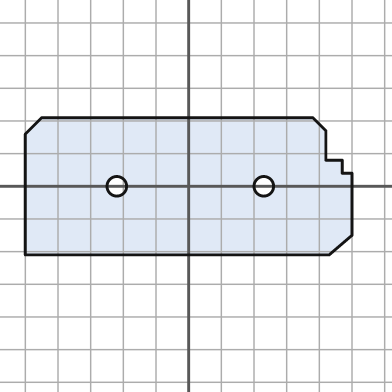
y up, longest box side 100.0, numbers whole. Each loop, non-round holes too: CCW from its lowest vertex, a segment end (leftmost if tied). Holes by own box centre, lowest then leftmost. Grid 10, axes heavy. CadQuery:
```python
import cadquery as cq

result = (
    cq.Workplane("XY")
    .moveTo(-50.0, -21.0)
    .lineTo(43.0, -21.0)
    .lineTo(50.0, -15.0)
    .lineTo(50.0, 4.0)
    .lineTo(47.0, 4.0)
    .lineTo(47.0, 8.0)
    .lineTo(42.0, 8.0)
    .lineTo(42.0, 17.0)
    .lineTo(38.0, 21.0)
    .lineTo(-45.0, 21.0)
    .lineTo(-50.0, 16.0)
    .close()
    .moveTo(-22.0, 0.0)
    .circle(3.0)
    .moveTo(23.0, 0.0)
    .circle(3.0)
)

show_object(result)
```